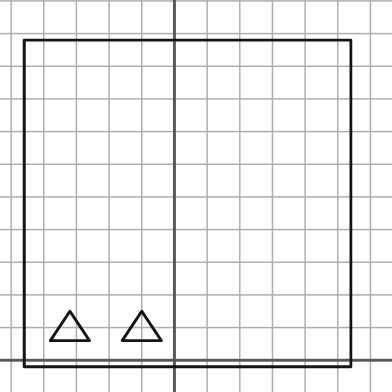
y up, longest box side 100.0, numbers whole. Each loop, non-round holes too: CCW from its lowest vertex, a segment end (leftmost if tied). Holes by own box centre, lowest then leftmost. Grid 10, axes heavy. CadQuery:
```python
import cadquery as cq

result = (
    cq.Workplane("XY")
    .moveTo(-46.0, -2.0)
    .lineTo(54.0, -2.0)
    .lineTo(54.0, 98.0)
    .lineTo(-46.0, 98.0)
    .close()
    .moveTo(-38.0, 6.0)
    .lineTo(-26.0, 6.0)
    .lineTo(-32.0, 15.0)
    .close()
    .moveTo(-16.0, 6.0)
    .lineTo(-4.0, 6.0)
    .lineTo(-10.0, 15.0)
    .close()
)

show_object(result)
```